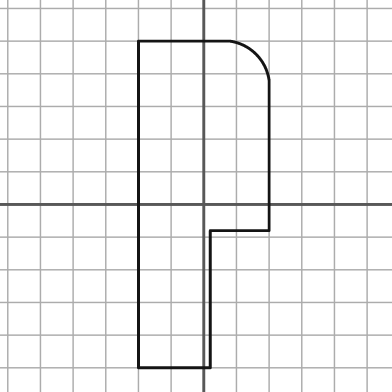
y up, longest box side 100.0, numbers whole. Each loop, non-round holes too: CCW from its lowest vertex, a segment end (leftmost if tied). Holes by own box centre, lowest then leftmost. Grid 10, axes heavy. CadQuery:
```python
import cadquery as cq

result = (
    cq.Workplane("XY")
    .moveTo(-20.0, -50.0)
    .lineTo(2.0, -50.0)
    .lineTo(2.0, -8.0)
    .lineTo(20.0, -8.0)
    .lineTo(20.0, 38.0)
    .threePointArc((16.0, 46.0), (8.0, 50.0))
    .lineTo(-20.0, 50.0)
    .close()
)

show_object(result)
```